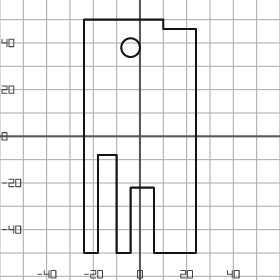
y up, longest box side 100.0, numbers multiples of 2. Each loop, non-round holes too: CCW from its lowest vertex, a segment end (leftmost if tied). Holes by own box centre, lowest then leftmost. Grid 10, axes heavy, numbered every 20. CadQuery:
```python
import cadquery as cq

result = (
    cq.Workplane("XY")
    .moveTo(-24.0, -50.0)
    .lineTo(-18.0, -50.0)
    .lineTo(-18.0, -8.0)
    .lineTo(-10.0, -8.0)
    .lineTo(-10.0, -50.0)
    .lineTo(-4.0, -50.0)
    .lineTo(-4.0, -22.0)
    .lineTo(6.0, -22.0)
    .lineTo(6.0, -50.0)
    .lineTo(24.0, -50.0)
    .lineTo(24.0, 46.0)
    .lineTo(10.0, 46.0)
    .lineTo(10.0, 50.0)
    .lineTo(-24.0, 50.0)
    .close()
    .moveTo(-4.0, 38.0)
    .circle(4.0)
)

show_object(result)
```